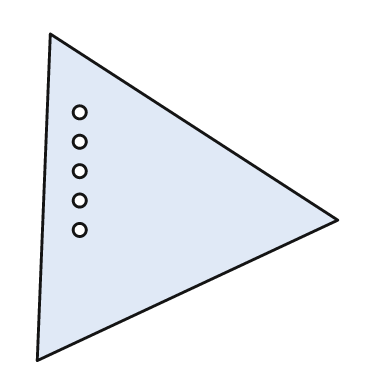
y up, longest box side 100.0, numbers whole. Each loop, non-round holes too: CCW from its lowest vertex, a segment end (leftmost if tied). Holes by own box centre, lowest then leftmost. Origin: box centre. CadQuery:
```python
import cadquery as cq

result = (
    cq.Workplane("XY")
    .moveTo(-46.0, -50.0)
    .lineTo(46.0, -7.0)
    .lineTo(-42.0, 50.0)
    .close()
    .moveTo(-33.0, -10.0)
    .circle(2.0)
    .moveTo(-33.0, -1.0)
    .circle(2.0)
    .moveTo(-33.0, 8.0)
    .circle(2.0)
    .moveTo(-33.0, 17.0)
    .circle(2.0)
    .moveTo(-33.0, 26.0)
    .circle(2.0)
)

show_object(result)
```